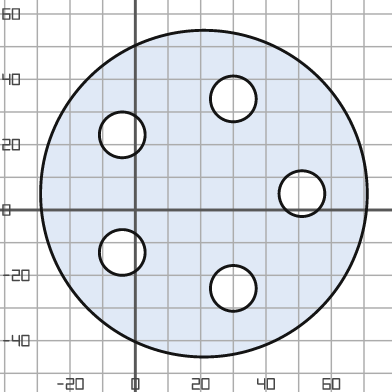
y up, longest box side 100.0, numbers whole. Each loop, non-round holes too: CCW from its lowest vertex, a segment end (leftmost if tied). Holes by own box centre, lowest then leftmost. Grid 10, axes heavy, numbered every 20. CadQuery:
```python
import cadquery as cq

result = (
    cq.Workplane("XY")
    .moveTo(21.0, 5.0)
    .circle(50.0)
    .moveTo(30.0, -24.0)
    .circle(7.0)
    .moveTo(-4.0, -13.0)
    .circle(7.0)
    .moveTo(51.0, 5.0)
    .circle(7.0)
    .moveTo(-4.0, 23.0)
    .circle(7.0)
    .moveTo(30.0, 34.0)
    .circle(7.0)
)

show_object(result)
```